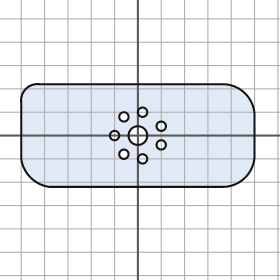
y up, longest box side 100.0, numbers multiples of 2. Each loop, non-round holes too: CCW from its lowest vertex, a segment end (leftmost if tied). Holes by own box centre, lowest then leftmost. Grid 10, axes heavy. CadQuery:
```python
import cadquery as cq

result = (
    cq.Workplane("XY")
    .moveTo(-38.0, -22.0)
    .lineTo(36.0, -22.0)
    .threePointArc((46.0, -18.0), (50.0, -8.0))
    .lineTo(50.0, 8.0)
    .threePointArc((46.0, 18.0), (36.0, 22.0))
    .lineTo(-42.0, 22.0)
    .threePointArc((-48.0, 20.0), (-50.0, 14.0))
    .lineTo(-50.0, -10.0)
    .threePointArc((-46.0, -18.0), (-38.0, -22.0))
    .close()
    .moveTo(2.0, -10.0)
    .circle(2.0)
    .moveTo(-6.0, -8.0)
    .circle(2.0)
    .moveTo(10.0, -4.0)
    .circle(2.0)
    .moveTo(-10.0, 0.0)
    .circle(2.0)
    .moveTo(0.0, 0.0)
    .circle(4.0)
    .moveTo(10.0, 4.0)
    .circle(2.0)
    .moveTo(-6.0, 8.0)
    .circle(2.0)
    .moveTo(2.0, 10.0)
    .circle(2.0)
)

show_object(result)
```